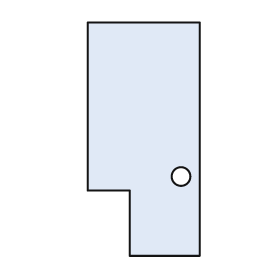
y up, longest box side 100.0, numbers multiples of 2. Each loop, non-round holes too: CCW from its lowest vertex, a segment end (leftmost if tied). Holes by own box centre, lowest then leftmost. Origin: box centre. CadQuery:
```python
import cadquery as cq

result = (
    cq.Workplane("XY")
    .moveTo(-6.0, -50.0)
    .lineTo(24.0, -50.0)
    .lineTo(24.0, 50.0)
    .lineTo(-24.0, 50.0)
    .lineTo(-24.0, -22.0)
    .lineTo(-6.0, -22.0)
    .close()
    .moveTo(16.0, -16.0)
    .circle(4.0)
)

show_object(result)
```